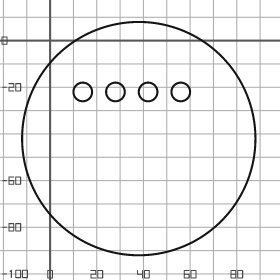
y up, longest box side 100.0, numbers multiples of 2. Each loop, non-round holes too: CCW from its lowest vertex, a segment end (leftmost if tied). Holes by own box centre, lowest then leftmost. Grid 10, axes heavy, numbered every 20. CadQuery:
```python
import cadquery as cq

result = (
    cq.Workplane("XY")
    .moveTo(38.0, -42.0)
    .circle(50.0)
    .moveTo(14.0, -22.0)
    .circle(4.0)
    .moveTo(28.0, -22.0)
    .circle(4.0)
    .moveTo(42.0, -22.0)
    .circle(4.0)
    .moveTo(56.0, -22.0)
    .circle(4.0)
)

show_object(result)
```